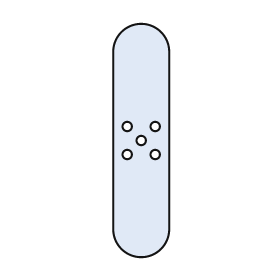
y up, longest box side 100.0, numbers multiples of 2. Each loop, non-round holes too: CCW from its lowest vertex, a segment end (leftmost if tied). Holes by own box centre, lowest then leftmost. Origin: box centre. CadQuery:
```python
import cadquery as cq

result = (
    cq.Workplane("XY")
    .moveTo(-12.0, -38.0)
    .threePointArc((0.0, -50.0), (12.0, -38.0))
    .lineTo(12.0, 38.0)
    .threePointArc((0.0, 50.0), (-12.0, 38.0))
    .close()
    .moveTo(-6.0, -6.0)
    .circle(2.0)
    .moveTo(6.0, -6.0)
    .circle(2.0)
    .moveTo(0.0, 0.0)
    .circle(2.0)
    .moveTo(-6.0, 6.0)
    .circle(2.0)
    .moveTo(6.0, 6.0)
    .circle(2.0)
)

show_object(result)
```